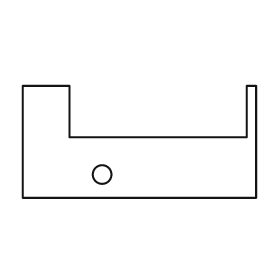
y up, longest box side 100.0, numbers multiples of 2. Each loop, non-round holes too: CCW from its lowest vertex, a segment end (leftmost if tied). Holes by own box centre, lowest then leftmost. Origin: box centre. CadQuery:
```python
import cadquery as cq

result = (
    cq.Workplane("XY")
    .moveTo(-50.0, -24.0)
    .lineTo(50.0, -24.0)
    .lineTo(50.0, 24.0)
    .lineTo(46.0, 24.0)
    .lineTo(46.0, 2.0)
    .lineTo(-30.0, 2.0)
    .lineTo(-30.0, 24.0)
    .lineTo(-50.0, 24.0)
    .close()
    .moveTo(-16.0, -14.0)
    .circle(4.0)
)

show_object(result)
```